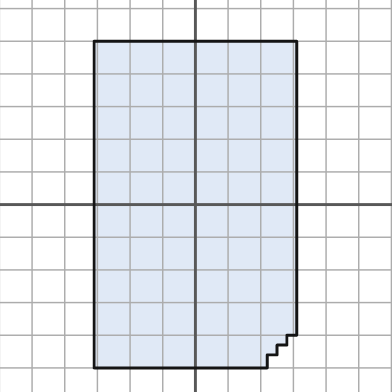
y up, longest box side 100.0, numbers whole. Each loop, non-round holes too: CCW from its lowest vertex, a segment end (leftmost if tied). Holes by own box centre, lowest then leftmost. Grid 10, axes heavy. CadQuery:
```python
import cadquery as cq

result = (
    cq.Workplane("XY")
    .moveTo(-31.0, -50.0)
    .lineTo(22.0, -50.0)
    .lineTo(22.0, -46.0)
    .lineTo(25.0, -46.0)
    .lineTo(25.0, -43.0)
    .lineTo(28.0, -43.0)
    .lineTo(28.0, -40.0)
    .lineTo(31.0, -40.0)
    .lineTo(31.0, 50.0)
    .lineTo(-31.0, 50.0)
    .close()
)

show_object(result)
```